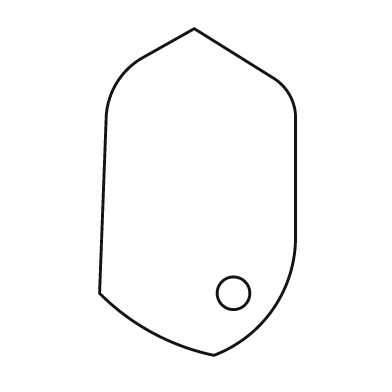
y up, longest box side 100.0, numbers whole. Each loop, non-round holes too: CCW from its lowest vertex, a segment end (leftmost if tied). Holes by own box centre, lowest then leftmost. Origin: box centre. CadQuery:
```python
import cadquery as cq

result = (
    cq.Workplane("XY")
    .moveTo(5.0, -50.0)
    .threePointArc((23.0, -36.0), (30.0, -14.0))
    .lineTo(30.0, 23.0)
    .threePointArc((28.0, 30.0), (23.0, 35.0))
    .lineTo(-1.0, 50.0)
    .lineTo(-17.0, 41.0)
    .threePointArc((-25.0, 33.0), (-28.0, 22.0))
    .lineTo(-30.0, -31.0)
    .threePointArc((-14.0, -43.0), (5.0, -50.0))
    .close()
    .moveTo(11.0, -31.0)
    .circle(5.0)
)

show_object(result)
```